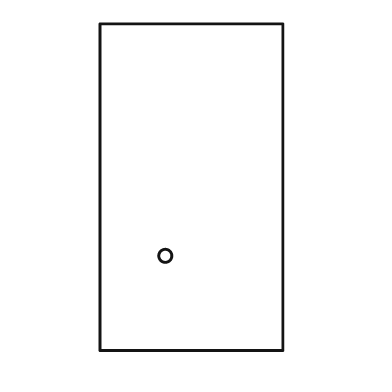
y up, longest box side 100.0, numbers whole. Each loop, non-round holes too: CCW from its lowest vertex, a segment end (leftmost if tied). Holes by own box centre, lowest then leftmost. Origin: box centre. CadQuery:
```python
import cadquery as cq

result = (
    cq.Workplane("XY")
    .moveTo(-28.0, -50.0)
    .lineTo(28.0, -50.0)
    .lineTo(28.0, 50.0)
    .lineTo(-28.0, 50.0)
    .close()
    .moveTo(-8.0, -21.0)
    .circle(2.0)
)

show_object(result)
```